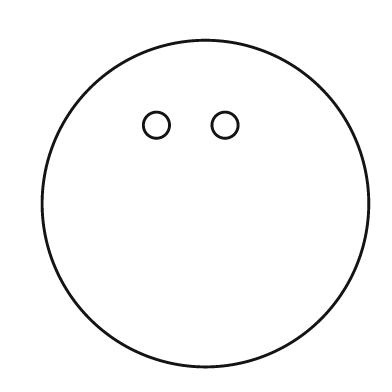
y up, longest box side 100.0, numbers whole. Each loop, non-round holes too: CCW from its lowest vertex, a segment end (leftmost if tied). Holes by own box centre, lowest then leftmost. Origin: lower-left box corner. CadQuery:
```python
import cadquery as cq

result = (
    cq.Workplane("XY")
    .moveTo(50.0, 50.0)
    .circle(50.0)
    .moveTo(35.0, 74.0)
    .circle(4.0)
    .moveTo(56.0, 74.0)
    .circle(4.0)
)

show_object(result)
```